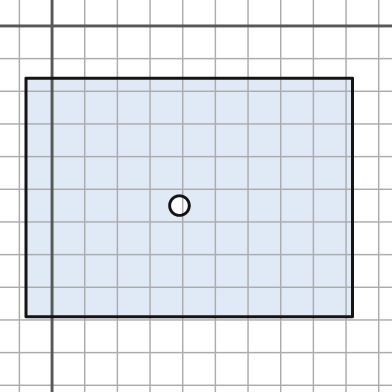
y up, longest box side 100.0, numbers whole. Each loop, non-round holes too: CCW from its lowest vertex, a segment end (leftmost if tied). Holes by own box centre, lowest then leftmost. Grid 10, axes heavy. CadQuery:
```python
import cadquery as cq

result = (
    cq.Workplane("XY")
    .moveTo(-8.0, -89.0)
    .lineTo(92.0, -89.0)
    .lineTo(92.0, -16.0)
    .lineTo(-8.0, -16.0)
    .close()
    .moveTo(39.0, -55.0)
    .circle(3.0)
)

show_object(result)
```